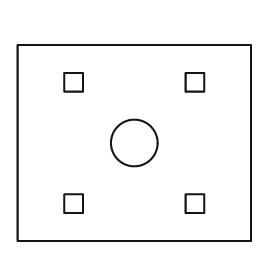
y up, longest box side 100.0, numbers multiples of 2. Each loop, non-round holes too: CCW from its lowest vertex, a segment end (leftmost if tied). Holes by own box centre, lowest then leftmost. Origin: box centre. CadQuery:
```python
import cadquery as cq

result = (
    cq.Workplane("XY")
    .moveTo(-50.0, -42.0)
    .lineTo(50.0, -42.0)
    .lineTo(50.0, 42.0)
    .lineTo(-50.0, 42.0)
    .close()
    .moveTo(-30.0, -30.0)
    .lineTo(-22.0, -30.0)
    .lineTo(-22.0, -22.0)
    .lineTo(-30.0, -22.0)
    .close()
    .moveTo(22.0, -30.0)
    .lineTo(30.0, -30.0)
    .lineTo(30.0, -22.0)
    .lineTo(22.0, -22.0)
    .close()
    .moveTo(0.0, 0.0)
    .circle(10.0)
    .moveTo(-30.0, 22.0)
    .lineTo(-22.0, 22.0)
    .lineTo(-22.0, 30.0)
    .lineTo(-30.0, 30.0)
    .close()
    .moveTo(22.0, 22.0)
    .lineTo(30.0, 22.0)
    .lineTo(30.0, 30.0)
    .lineTo(22.0, 30.0)
    .close()
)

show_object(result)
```